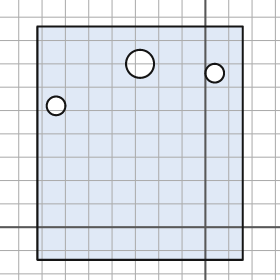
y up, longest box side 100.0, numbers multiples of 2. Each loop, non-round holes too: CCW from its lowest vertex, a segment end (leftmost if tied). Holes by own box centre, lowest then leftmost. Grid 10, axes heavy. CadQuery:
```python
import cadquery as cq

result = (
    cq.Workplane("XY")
    .moveTo(-72.0, -14.0)
    .lineTo(16.0, -14.0)
    .lineTo(16.0, 86.0)
    .lineTo(-72.0, 86.0)
    .close()
    .moveTo(-64.0, 52.0)
    .circle(4.0)
    .moveTo(4.0, 66.0)
    .circle(4.0)
    .moveTo(-28.0, 70.0)
    .circle(6.0)
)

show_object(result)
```